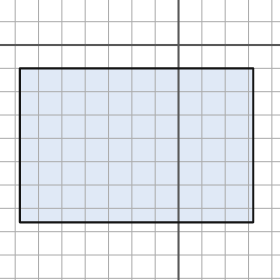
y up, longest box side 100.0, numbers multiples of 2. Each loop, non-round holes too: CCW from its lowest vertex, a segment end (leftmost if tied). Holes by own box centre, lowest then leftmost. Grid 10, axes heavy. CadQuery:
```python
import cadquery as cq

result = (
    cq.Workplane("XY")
    .moveTo(-68.0, -76.0)
    .lineTo(32.0, -76.0)
    .lineTo(32.0, -10.0)
    .lineTo(-68.0, -10.0)
    .close()
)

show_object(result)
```